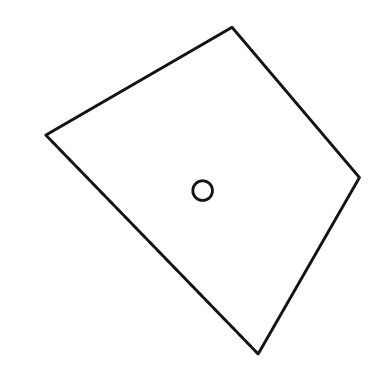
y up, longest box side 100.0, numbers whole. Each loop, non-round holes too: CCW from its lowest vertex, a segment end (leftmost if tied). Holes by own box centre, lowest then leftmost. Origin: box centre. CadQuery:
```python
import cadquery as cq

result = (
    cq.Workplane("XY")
    .moveTo(17.0, -50.0)
    .lineTo(48.0, 4.0)
    .lineTo(9.0, 50.0)
    .lineTo(-48.0, 17.0)
    .close()
    .moveTo(0.0, 0.0)
    .circle(3.0)
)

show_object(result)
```